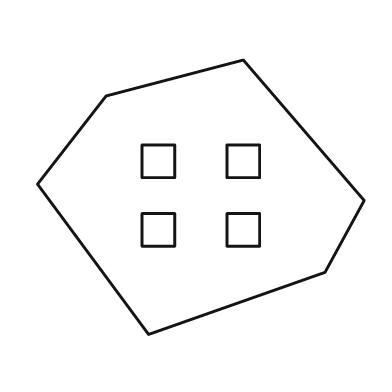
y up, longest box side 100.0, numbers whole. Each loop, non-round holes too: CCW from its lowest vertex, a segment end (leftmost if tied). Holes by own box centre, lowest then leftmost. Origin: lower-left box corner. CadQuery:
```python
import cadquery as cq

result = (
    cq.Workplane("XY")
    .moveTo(34.0, 0.0)
    .lineTo(88.0, 19.0)
    .lineTo(100.0, 41.0)
    .lineTo(63.0, 84.0)
    .lineTo(21.0, 73.0)
    .lineTo(0.0, 46.0)
    .close()
    .moveTo(32.0, 27.0)
    .lineTo(42.0, 27.0)
    .lineTo(42.0, 37.0)
    .lineTo(32.0, 37.0)
    .close()
    .moveTo(58.0, 27.0)
    .lineTo(68.0, 27.0)
    .lineTo(68.0, 37.0)
    .lineTo(58.0, 37.0)
    .close()
    .moveTo(32.0, 48.0)
    .lineTo(42.0, 48.0)
    .lineTo(42.0, 58.0)
    .lineTo(32.0, 58.0)
    .close()
    .moveTo(58.0, 48.0)
    .lineTo(68.0, 48.0)
    .lineTo(68.0, 58.0)
    .lineTo(58.0, 58.0)
    .close()
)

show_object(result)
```